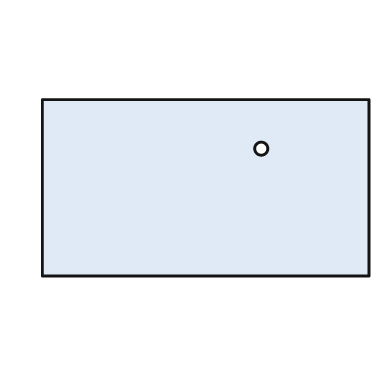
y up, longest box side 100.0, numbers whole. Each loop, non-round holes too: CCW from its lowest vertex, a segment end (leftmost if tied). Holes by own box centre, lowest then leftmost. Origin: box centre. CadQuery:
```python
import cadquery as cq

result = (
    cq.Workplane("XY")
    .moveTo(-50.0, -27.0)
    .lineTo(50.0, -27.0)
    .lineTo(50.0, 27.0)
    .lineTo(-50.0, 27.0)
    .close()
    .moveTo(17.0, 12.0)
    .circle(2.0)
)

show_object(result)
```